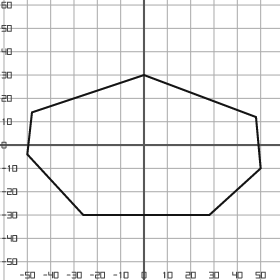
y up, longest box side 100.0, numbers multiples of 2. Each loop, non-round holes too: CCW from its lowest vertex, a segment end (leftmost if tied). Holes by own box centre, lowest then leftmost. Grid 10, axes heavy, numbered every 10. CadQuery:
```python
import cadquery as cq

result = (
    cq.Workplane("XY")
    .moveTo(-26.0, -30.0)
    .lineTo(28.0, -30.0)
    .lineTo(50.0, -10.0)
    .lineTo(48.0, 12.0)
    .lineTo(0.0, 30.0)
    .lineTo(-48.0, 14.0)
    .lineTo(-50.0, -4.0)
    .close()
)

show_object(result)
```